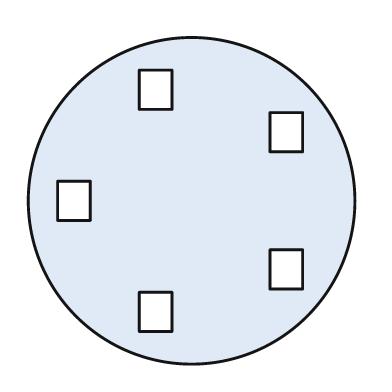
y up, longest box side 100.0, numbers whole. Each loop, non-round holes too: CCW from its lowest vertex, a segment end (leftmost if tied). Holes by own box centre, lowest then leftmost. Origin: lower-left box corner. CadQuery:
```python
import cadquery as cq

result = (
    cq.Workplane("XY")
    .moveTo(50.0, 50.0)
    .circle(50.0)
    .moveTo(34.0, 10.0)
    .lineTo(44.0, 10.0)
    .lineTo(44.0, 22.0)
    .lineTo(34.0, 22.0)
    .close()
    .moveTo(74.0, 23.0)
    .lineTo(84.0, 23.0)
    .lineTo(84.0, 35.0)
    .lineTo(74.0, 35.0)
    .close()
    .moveTo(9.0, 44.0)
    .lineTo(19.0, 44.0)
    .lineTo(19.0, 56.0)
    .lineTo(9.0, 56.0)
    .close()
    .moveTo(74.0, 65.0)
    .lineTo(84.0, 65.0)
    .lineTo(84.0, 77.0)
    .lineTo(74.0, 77.0)
    .close()
    .moveTo(34.0, 78.0)
    .lineTo(44.0, 78.0)
    .lineTo(44.0, 90.0)
    .lineTo(34.0, 90.0)
    .close()
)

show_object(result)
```